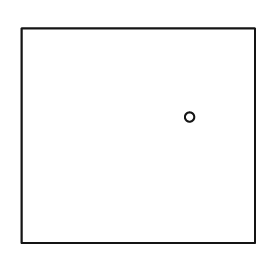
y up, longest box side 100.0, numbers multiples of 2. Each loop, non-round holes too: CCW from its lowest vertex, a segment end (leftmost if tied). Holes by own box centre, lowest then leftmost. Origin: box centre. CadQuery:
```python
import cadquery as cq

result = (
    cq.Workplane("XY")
    .moveTo(-50.0, -46.0)
    .lineTo(50.0, -46.0)
    .lineTo(50.0, 46.0)
    .lineTo(-50.0, 46.0)
    .close()
    .moveTo(22.0, 8.0)
    .circle(2.0)
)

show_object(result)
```